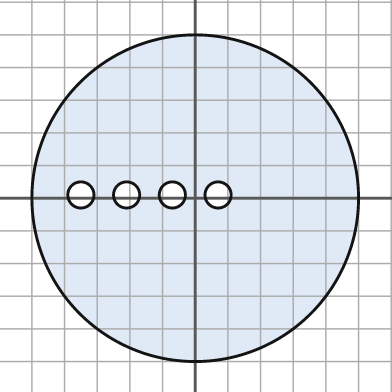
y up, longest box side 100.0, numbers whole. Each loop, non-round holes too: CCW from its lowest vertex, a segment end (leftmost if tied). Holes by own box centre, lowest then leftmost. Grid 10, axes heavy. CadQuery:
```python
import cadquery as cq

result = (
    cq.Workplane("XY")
    .moveTo(0.0, 0.0)
    .circle(50.0)
    .moveTo(-35.0, 1.0)
    .circle(4.0)
    .moveTo(-21.0, 1.0)
    .circle(4.0)
    .moveTo(-7.0, 1.0)
    .circle(4.0)
    .moveTo(7.0, 1.0)
    .circle(4.0)
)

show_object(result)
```